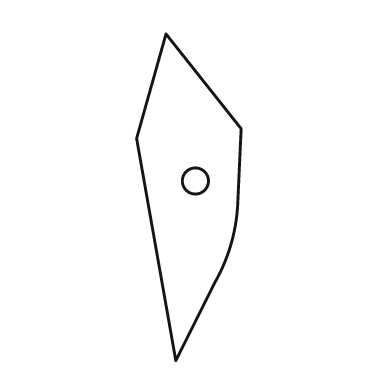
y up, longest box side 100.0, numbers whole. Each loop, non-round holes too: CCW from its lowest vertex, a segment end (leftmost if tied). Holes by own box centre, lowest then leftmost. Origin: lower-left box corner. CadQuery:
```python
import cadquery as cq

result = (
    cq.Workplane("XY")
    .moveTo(12.0, 0.0)
    .lineTo(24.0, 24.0)
    .threePointArc((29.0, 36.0), (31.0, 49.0))
    .lineTo(32.0, 71.0)
    .lineTo(9.0, 100.0)
    .lineTo(0.0, 68.0)
    .close()
    .moveTo(18.0, 55.0)
    .circle(4.0)
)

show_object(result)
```